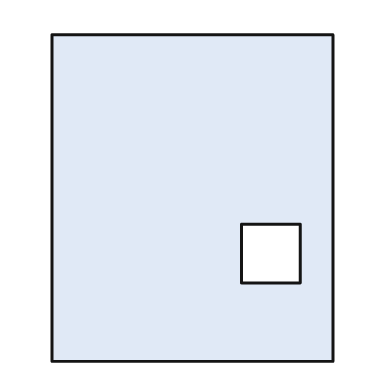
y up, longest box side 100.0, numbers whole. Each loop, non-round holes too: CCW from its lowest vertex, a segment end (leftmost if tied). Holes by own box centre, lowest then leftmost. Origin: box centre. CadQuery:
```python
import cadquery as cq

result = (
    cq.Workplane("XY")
    .moveTo(-43.0, -50.0)
    .lineTo(43.0, -50.0)
    .lineTo(43.0, 50.0)
    .lineTo(-43.0, 50.0)
    .close()
    .moveTo(15.0, -26.0)
    .lineTo(33.0, -26.0)
    .lineTo(33.0, -8.0)
    .lineTo(15.0, -8.0)
    .close()
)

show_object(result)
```